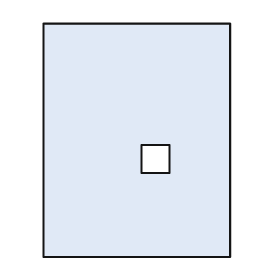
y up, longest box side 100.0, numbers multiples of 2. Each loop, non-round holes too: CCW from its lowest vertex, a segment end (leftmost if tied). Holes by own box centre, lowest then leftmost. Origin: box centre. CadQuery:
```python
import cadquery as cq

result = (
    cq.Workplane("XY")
    .moveTo(-40.0, -50.0)
    .lineTo(40.0, -50.0)
    .lineTo(40.0, 50.0)
    .lineTo(-40.0, 50.0)
    .close()
    .moveTo(2.0, -14.0)
    .lineTo(14.0, -14.0)
    .lineTo(14.0, -2.0)
    .lineTo(2.0, -2.0)
    .close()
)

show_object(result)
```